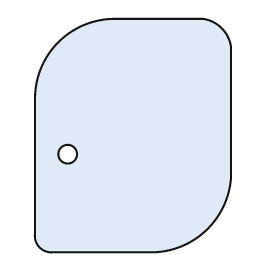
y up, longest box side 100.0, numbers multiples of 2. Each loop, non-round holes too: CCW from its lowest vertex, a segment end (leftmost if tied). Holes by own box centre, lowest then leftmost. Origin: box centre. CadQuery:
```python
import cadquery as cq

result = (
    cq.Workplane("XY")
    .moveTo(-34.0, -50.0)
    .lineTo(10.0, -50.0)
    .threePointArc((32.0, -40.0), (42.0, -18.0))
    .lineTo(42.0, 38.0)
    .threePointArc((38.0, 46.0), (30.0, 50.0))
    .lineTo(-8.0, 50.0)
    .threePointArc((-32.0, 40.0), (-42.0, 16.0))
    .lineTo(-42.0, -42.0)
    .threePointArc((-40.0, -48.0), (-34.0, -50.0))
    .close()
    .moveTo(-28.0, -8.0)
    .circle(4.0)
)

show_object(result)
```